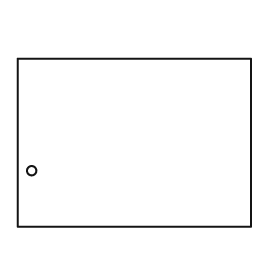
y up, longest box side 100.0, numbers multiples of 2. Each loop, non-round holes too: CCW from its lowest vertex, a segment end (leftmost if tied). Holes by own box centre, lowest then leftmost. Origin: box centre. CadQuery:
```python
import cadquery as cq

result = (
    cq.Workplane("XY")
    .moveTo(-50.0, -36.0)
    .lineTo(50.0, -36.0)
    .lineTo(50.0, 36.0)
    .lineTo(-50.0, 36.0)
    .close()
    .moveTo(-44.0, -12.0)
    .circle(2.0)
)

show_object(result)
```